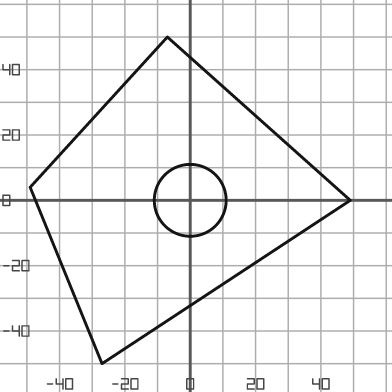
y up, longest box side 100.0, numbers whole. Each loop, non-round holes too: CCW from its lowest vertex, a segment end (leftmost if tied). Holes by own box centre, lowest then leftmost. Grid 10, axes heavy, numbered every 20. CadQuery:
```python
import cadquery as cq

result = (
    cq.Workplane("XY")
    .moveTo(-27.0, -50.0)
    .lineTo(49.0, 0.0)
    .lineTo(-7.0, 50.0)
    .lineTo(-49.0, 4.0)
    .close()
    .moveTo(0.0, 0.0)
    .circle(11.0)
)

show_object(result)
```